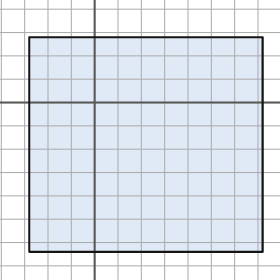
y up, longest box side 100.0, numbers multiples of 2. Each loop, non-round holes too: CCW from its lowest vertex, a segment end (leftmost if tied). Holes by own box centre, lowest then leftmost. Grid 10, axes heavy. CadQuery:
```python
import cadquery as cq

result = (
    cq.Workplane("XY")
    .moveTo(-28.0, -64.0)
    .lineTo(72.0, -64.0)
    .lineTo(72.0, 28.0)
    .lineTo(-28.0, 28.0)
    .close()
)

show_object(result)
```